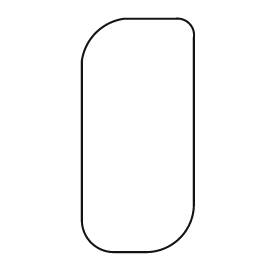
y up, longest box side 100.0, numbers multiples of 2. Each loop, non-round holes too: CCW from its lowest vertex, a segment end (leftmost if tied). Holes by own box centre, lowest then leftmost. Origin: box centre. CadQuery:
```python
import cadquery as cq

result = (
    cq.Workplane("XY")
    .moveTo(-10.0, -50.0)
    .lineTo(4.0, -50.0)
    .threePointArc((18.0, -44.0), (24.0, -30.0))
    .lineTo(24.0, 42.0)
    .threePointArc((22.0, 48.0), (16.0, 50.0))
    .lineTo(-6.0, 50.0)
    .threePointArc((-18.0, 44.0), (-24.0, 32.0))
    .lineTo(-24.0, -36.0)
    .threePointArc((-20.0, -46.0), (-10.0, -50.0))
    .close()
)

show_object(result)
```